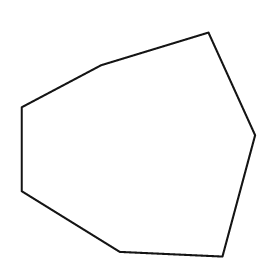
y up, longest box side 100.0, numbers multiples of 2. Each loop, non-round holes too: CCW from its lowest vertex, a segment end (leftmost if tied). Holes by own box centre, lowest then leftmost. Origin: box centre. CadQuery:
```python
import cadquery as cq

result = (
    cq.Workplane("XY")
    .moveTo(36.0, -48.0)
    .lineTo(50.0, 4.0)
    .lineTo(30.0, 48.0)
    .lineTo(-16.0, 34.0)
    .lineTo(-50.0, 16.0)
    .lineTo(-50.0, -20.0)
    .lineTo(-8.0, -46.0)
    .close()
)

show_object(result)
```